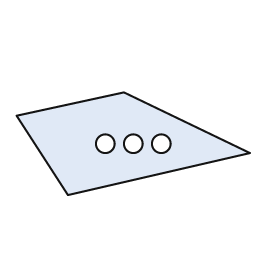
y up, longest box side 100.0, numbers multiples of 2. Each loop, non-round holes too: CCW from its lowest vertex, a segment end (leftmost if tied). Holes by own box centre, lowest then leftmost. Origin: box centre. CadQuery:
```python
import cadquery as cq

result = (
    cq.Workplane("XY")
    .moveTo(-28.0, -22.0)
    .lineTo(50.0, -4.0)
    .lineTo(-4.0, 22.0)
    .lineTo(-50.0, 12.0)
    .close()
    .moveTo(-12.0, 0.0)
    .circle(4.0)
    .moveTo(0.0, 0.0)
    .circle(4.0)
    .moveTo(12.0, 0.0)
    .circle(4.0)
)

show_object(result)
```